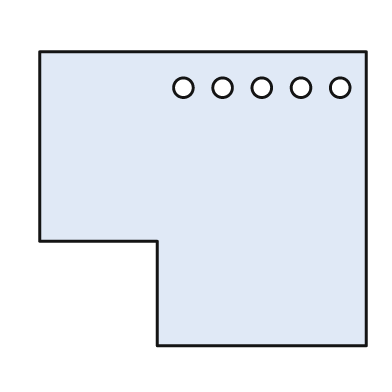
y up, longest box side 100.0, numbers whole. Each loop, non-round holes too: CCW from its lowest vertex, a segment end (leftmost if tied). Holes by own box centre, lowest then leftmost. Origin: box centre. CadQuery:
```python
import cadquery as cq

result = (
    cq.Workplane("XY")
    .moveTo(-14.0, -45.0)
    .lineTo(50.0, -45.0)
    .lineTo(50.0, 45.0)
    .lineTo(-50.0, 45.0)
    .lineTo(-50.0, -13.0)
    .lineTo(-14.0, -13.0)
    .close()
    .moveTo(-6.0, 34.0)
    .circle(3.0)
    .moveTo(6.0, 34.0)
    .circle(3.0)
    .moveTo(18.0, 34.0)
    .circle(3.0)
    .moveTo(30.0, 34.0)
    .circle(3.0)
    .moveTo(42.0, 34.0)
    .circle(3.0)
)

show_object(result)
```